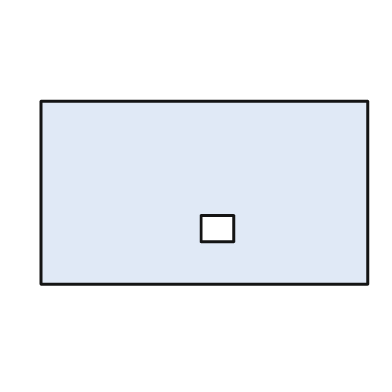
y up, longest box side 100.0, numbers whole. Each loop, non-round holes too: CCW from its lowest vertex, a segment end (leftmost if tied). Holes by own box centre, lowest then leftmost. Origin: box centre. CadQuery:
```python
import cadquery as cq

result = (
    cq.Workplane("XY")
    .moveTo(-50.0, -28.0)
    .lineTo(50.0, -28.0)
    .lineTo(50.0, 28.0)
    .lineTo(-50.0, 28.0)
    .close()
    .moveTo(-1.0, -15.0)
    .lineTo(9.0, -15.0)
    .lineTo(9.0, -7.0)
    .lineTo(-1.0, -7.0)
    .close()
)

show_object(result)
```